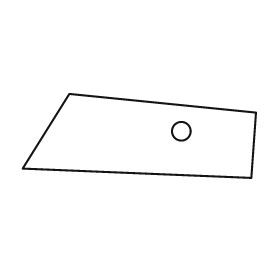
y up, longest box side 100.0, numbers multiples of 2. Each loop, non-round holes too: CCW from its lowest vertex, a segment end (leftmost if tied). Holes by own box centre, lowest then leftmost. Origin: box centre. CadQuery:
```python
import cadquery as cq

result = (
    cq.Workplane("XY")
    .moveTo(48.0, -18.0)
    .lineTo(50.0, 10.0)
    .lineTo(-30.0, 18.0)
    .lineTo(-50.0, -14.0)
    .close()
    .moveTo(18.0, 2.0)
    .circle(4.0)
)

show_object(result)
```